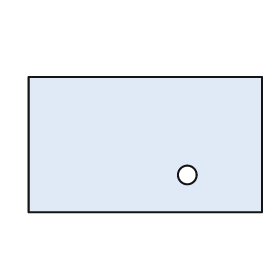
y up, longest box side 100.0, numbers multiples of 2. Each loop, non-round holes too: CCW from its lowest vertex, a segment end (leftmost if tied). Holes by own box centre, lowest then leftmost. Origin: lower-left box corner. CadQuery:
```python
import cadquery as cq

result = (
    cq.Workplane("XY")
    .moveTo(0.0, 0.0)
    .lineTo(100.0, 0.0)
    .lineTo(100.0, 58.0)
    .lineTo(0.0, 58.0)
    .close()
    .moveTo(68.0, 16.0)
    .circle(4.0)
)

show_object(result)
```